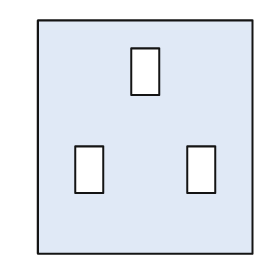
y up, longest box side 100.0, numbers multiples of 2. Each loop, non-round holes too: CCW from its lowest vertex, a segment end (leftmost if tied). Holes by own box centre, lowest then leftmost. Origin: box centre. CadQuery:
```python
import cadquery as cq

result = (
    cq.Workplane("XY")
    .moveTo(-46.0, -50.0)
    .lineTo(46.0, -50.0)
    .lineTo(46.0, 50.0)
    .lineTo(-46.0, 50.0)
    .close()
    .moveTo(-30.0, -24.0)
    .lineTo(-18.0, -24.0)
    .lineTo(-18.0, -4.0)
    .lineTo(-30.0, -4.0)
    .close()
    .moveTo(18.0, -24.0)
    .lineTo(30.0, -24.0)
    .lineTo(30.0, -4.0)
    .lineTo(18.0, -4.0)
    .close()
    .moveTo(-6.0, 18.0)
    .lineTo(6.0, 18.0)
    .lineTo(6.0, 38.0)
    .lineTo(-6.0, 38.0)
    .close()
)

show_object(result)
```